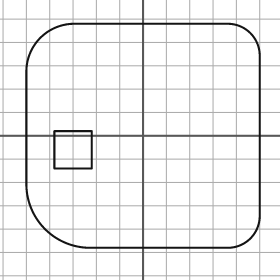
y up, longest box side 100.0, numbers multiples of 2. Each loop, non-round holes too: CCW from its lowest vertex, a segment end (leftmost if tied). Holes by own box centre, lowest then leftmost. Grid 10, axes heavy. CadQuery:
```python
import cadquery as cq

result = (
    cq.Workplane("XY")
    .moveTo(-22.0, -48.0)
    .lineTo(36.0, -48.0)
    .threePointArc((46.0, -44.0), (50.0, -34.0))
    .lineTo(50.0, 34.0)
    .threePointArc((46.0, 44.0), (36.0, 48.0))
    .lineTo(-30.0, 48.0)
    .threePointArc((-44.0, 42.0), (-50.0, 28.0))
    .lineTo(-50.0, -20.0)
    .threePointArc((-42.0, -40.0), (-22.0, -48.0))
    .close()
    .moveTo(-38.0, -14.0)
    .lineTo(-22.0, -14.0)
    .lineTo(-22.0, 2.0)
    .lineTo(-38.0, 2.0)
    .close()
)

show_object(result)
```